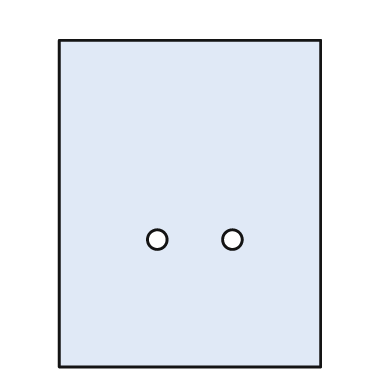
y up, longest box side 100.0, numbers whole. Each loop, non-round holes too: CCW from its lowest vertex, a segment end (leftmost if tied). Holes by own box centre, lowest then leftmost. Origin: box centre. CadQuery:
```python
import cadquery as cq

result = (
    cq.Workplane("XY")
    .moveTo(-40.0, -50.0)
    .lineTo(40.0, -50.0)
    .lineTo(40.0, 50.0)
    .lineTo(-40.0, 50.0)
    .close()
    .moveTo(-10.0, -11.0)
    .circle(3.0)
    .moveTo(13.0, -11.0)
    .circle(3.0)
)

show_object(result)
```